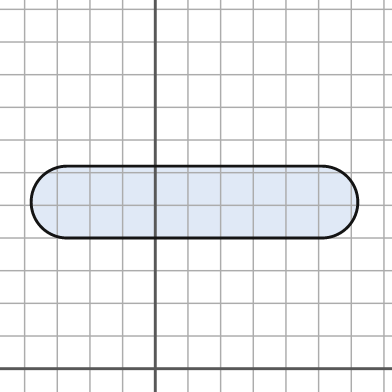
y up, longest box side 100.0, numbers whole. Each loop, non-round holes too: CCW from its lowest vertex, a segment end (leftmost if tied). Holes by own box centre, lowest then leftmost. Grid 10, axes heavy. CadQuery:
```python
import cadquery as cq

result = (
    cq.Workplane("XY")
    .moveTo(-27.0, 40.0)
    .lineTo(51.0, 40.0)
    .threePointArc((62.0, 51.0), (51.0, 62.0))
    .lineTo(-27.0, 62.0)
    .threePointArc((-38.0, 51.0), (-27.0, 40.0))
    .close()
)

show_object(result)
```